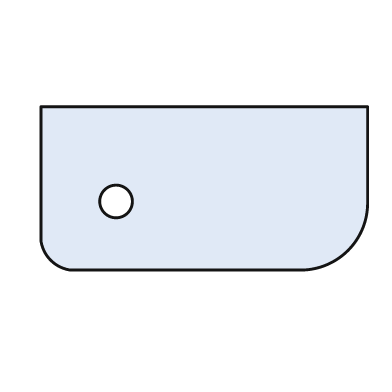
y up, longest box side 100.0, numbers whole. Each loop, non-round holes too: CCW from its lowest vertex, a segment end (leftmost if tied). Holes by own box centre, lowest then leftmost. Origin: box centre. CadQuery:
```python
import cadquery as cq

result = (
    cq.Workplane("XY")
    .moveTo(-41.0, -25.0)
    .lineTo(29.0, -25.0)
    .threePointArc((44.0, -19.0), (50.0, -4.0))
    .lineTo(50.0, 25.0)
    .lineTo(-50.0, 25.0)
    .lineTo(-50.0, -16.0)
    .threePointArc((-47.0, -22.0), (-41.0, -25.0))
    .close()
    .moveTo(-27.0, -4.0)
    .circle(5.0)
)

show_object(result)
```